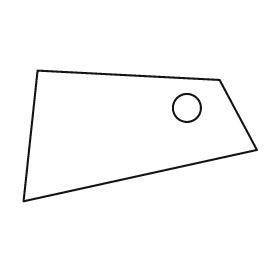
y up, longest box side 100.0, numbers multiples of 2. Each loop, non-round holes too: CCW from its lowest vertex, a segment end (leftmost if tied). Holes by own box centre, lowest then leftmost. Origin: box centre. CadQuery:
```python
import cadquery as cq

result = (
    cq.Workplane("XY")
    .moveTo(-50.0, -28.0)
    .lineTo(50.0, -6.0)
    .lineTo(34.0, 24.0)
    .lineTo(-44.0, 28.0)
    .close()
    .moveTo(20.0, 12.0)
    .circle(6.0)
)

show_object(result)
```